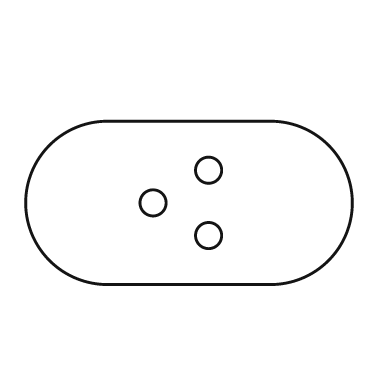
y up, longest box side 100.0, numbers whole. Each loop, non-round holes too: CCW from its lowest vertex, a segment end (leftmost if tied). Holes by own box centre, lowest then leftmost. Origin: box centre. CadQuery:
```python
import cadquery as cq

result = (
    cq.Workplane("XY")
    .moveTo(-25.0, -25.0)
    .lineTo(25.0, -25.0)
    .threePointArc((50.0, 0.0), (25.0, 25.0))
    .lineTo(-25.0, 25.0)
    .threePointArc((-50.0, 0.0), (-25.0, -25.0))
    .close()
    .moveTo(6.0, -10.0)
    .circle(4.0)
    .moveTo(-11.0, 0.0)
    .circle(4.0)
    .moveTo(6.0, 10.0)
    .circle(4.0)
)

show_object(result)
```